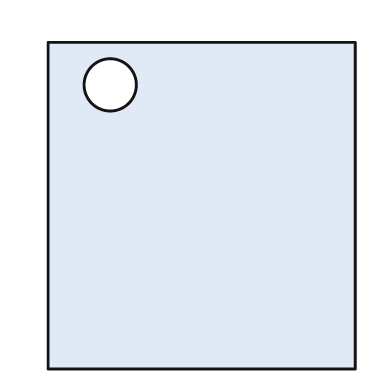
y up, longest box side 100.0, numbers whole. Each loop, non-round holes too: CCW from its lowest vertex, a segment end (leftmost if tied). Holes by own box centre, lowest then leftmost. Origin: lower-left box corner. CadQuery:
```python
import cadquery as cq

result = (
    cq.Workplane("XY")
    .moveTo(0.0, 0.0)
    .lineTo(94.0, 0.0)
    .lineTo(94.0, 100.0)
    .lineTo(0.0, 100.0)
    .close()
    .moveTo(19.0, 87.0)
    .circle(8.0)
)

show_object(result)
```